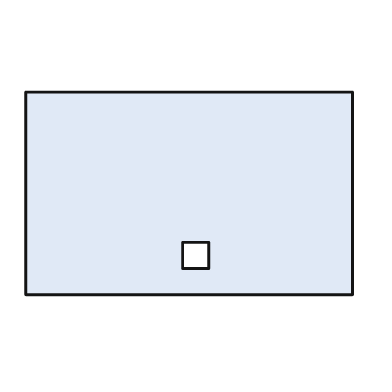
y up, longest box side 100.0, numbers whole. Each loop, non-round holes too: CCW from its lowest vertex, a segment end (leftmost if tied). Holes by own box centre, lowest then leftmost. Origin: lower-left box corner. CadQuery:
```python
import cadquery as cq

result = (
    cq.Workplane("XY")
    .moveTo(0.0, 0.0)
    .lineTo(100.0, 0.0)
    .lineTo(100.0, 62.0)
    .lineTo(0.0, 62.0)
    .close()
    .moveTo(48.0, 8.0)
    .lineTo(56.0, 8.0)
    .lineTo(56.0, 16.0)
    .lineTo(48.0, 16.0)
    .close()
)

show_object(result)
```